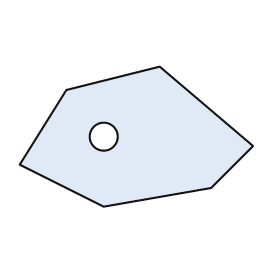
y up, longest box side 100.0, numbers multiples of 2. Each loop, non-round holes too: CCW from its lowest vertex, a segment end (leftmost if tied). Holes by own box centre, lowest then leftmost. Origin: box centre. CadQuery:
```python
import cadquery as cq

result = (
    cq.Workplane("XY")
    .moveTo(-14.0, -30.0)
    .lineTo(32.0, -22.0)
    .lineTo(50.0, -4.0)
    .lineTo(10.0, 30.0)
    .lineTo(-30.0, 20.0)
    .lineTo(-50.0, -12.0)
    .close()
    .moveTo(-14.0, 0.0)
    .circle(6.0)
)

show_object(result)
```